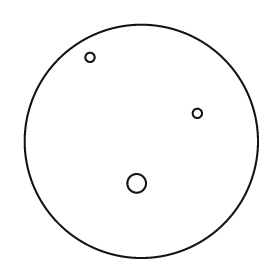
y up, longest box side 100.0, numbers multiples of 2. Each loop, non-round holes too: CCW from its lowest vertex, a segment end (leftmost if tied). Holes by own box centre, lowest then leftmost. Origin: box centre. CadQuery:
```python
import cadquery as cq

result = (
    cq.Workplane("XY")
    .moveTo(0.0, 0.0)
    .circle(50.0)
    .moveTo(-2.0, -18.0)
    .circle(4.0)
    .moveTo(24.0, 12.0)
    .circle(2.0)
    .moveTo(-22.0, 36.0)
    .circle(2.0)
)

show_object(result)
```